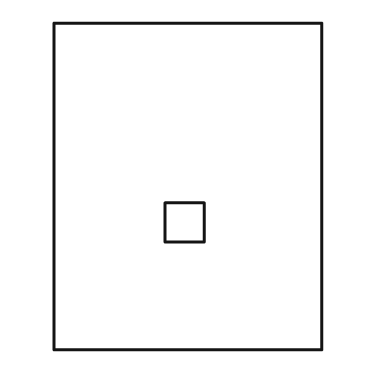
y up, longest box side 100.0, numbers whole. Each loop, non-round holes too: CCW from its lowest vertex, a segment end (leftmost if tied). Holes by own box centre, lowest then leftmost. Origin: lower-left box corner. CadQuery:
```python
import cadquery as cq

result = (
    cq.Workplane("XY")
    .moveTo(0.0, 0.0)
    .lineTo(82.0, 0.0)
    .lineTo(82.0, 100.0)
    .lineTo(0.0, 100.0)
    .close()
    .moveTo(34.0, 33.0)
    .lineTo(46.0, 33.0)
    .lineTo(46.0, 45.0)
    .lineTo(34.0, 45.0)
    .close()
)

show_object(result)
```